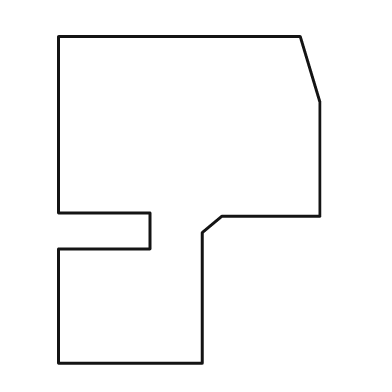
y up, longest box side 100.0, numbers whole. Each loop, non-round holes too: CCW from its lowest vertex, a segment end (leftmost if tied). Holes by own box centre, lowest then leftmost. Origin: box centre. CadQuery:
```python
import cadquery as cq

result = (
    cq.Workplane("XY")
    .moveTo(-40.0, -50.0)
    .lineTo(4.0, -50.0)
    .lineTo(4.0, -10.0)
    .lineTo(10.0, -5.0)
    .lineTo(40.0, -5.0)
    .lineTo(40.0, 30.0)
    .lineTo(34.0, 50.0)
    .lineTo(-40.0, 50.0)
    .lineTo(-40.0, -4.0)
    .lineTo(-12.0, -4.0)
    .lineTo(-12.0, -15.0)
    .lineTo(-40.0, -15.0)
    .close()
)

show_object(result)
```